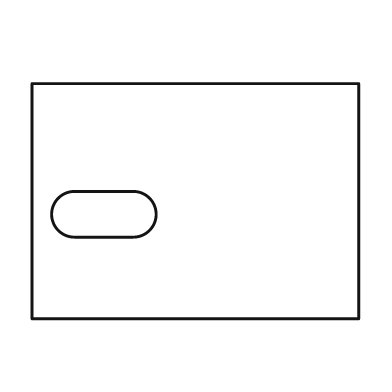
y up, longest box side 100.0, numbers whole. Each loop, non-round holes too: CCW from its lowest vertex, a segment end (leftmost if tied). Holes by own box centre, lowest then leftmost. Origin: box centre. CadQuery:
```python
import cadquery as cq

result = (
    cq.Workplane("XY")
    .moveTo(-50.0, -36.0)
    .lineTo(50.0, -36.0)
    .lineTo(50.0, 36.0)
    .lineTo(-50.0, 36.0)
    .close()
    .moveTo(-37.0, -11.0)
    .lineTo(-19.0, -11.0)
    .threePointArc((-12.0, -4.0), (-19.0, 3.0))
    .lineTo(-37.0, 3.0)
    .threePointArc((-44.0, -4.0), (-37.0, -11.0))
    .close()
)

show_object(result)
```